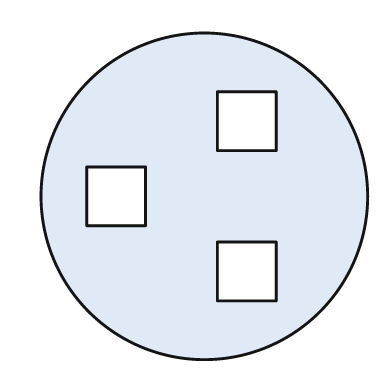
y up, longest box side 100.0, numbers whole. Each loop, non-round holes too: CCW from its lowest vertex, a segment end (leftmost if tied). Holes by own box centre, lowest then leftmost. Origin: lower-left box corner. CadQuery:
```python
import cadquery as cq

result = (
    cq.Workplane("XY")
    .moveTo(50.0, 50.0)
    .circle(50.0)
    .moveTo(54.0, 18.0)
    .lineTo(72.0, 18.0)
    .lineTo(72.0, 36.0)
    .lineTo(54.0, 36.0)
    .close()
    .moveTo(14.0, 41.0)
    .lineTo(32.0, 41.0)
    .lineTo(32.0, 59.0)
    .lineTo(14.0, 59.0)
    .close()
    .moveTo(54.0, 64.0)
    .lineTo(72.0, 64.0)
    .lineTo(72.0, 82.0)
    .lineTo(54.0, 82.0)
    .close()
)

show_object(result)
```